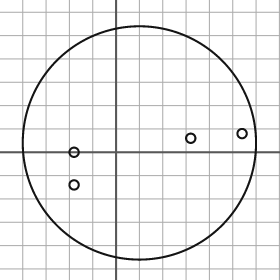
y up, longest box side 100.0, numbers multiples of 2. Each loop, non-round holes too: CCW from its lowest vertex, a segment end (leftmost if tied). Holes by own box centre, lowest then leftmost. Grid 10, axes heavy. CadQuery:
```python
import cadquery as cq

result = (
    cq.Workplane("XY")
    .moveTo(10.0, 4.0)
    .circle(50.0)
    .moveTo(-18.0, -14.0)
    .circle(2.0)
    .moveTo(-18.0, 0.0)
    .circle(2.0)
    .moveTo(32.0, 6.0)
    .circle(2.0)
    .moveTo(54.0, 8.0)
    .circle(2.0)
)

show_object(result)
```